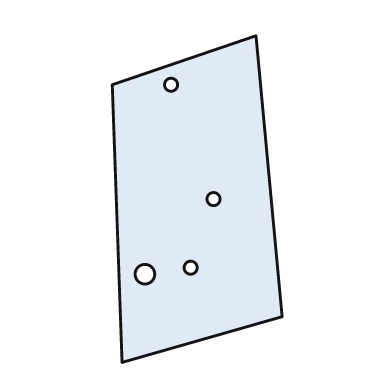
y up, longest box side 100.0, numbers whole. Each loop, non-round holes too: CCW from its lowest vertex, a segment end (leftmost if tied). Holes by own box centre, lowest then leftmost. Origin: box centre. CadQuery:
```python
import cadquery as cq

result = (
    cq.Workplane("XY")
    .moveTo(-23.0, -50.0)
    .lineTo(26.0, -36.0)
    .lineTo(18.0, 50.0)
    .lineTo(-26.0, 35.0)
    .close()
    .moveTo(-16.0, -23.0)
    .circle(3.0)
    .moveTo(-2.0, -21.0)
    .circle(2.0)
    .moveTo(5.0, 0.0)
    .circle(2.0)
    .moveTo(-8.0, 35.0)
    .circle(2.0)
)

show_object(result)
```